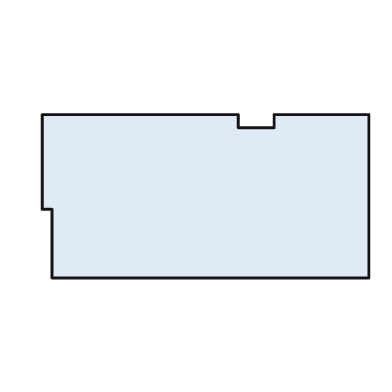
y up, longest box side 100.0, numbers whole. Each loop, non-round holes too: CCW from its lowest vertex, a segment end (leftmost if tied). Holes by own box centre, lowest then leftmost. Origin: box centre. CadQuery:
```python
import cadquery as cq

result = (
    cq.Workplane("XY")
    .moveTo(-47.0, -25.0)
    .lineTo(50.0, -25.0)
    .lineTo(50.0, 25.0)
    .lineTo(21.0, 25.0)
    .lineTo(21.0, 21.0)
    .lineTo(10.0, 21.0)
    .lineTo(10.0, 25.0)
    .lineTo(-50.0, 25.0)
    .lineTo(-50.0, -4.0)
    .lineTo(-47.0, -4.0)
    .close()
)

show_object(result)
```